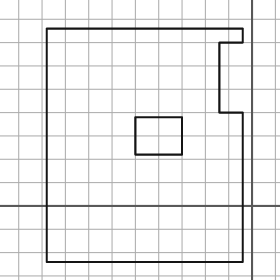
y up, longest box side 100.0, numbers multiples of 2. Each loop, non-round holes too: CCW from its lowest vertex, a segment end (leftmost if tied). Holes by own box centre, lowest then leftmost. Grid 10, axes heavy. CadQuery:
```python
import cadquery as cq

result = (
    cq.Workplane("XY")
    .moveTo(-88.0, -24.0)
    .lineTo(-4.0, -24.0)
    .lineTo(-4.0, 40.0)
    .lineTo(-14.0, 40.0)
    .lineTo(-14.0, 70.0)
    .lineTo(-4.0, 70.0)
    .lineTo(-4.0, 76.0)
    .lineTo(-88.0, 76.0)
    .close()
    .moveTo(-50.0, 22.0)
    .lineTo(-30.0, 22.0)
    .lineTo(-30.0, 38.0)
    .lineTo(-50.0, 38.0)
    .close()
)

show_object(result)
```